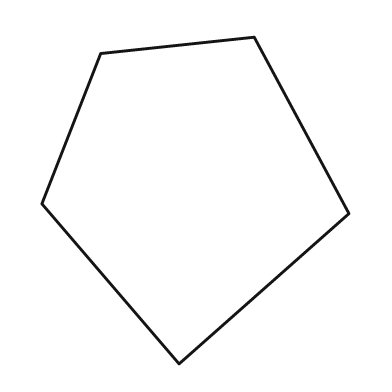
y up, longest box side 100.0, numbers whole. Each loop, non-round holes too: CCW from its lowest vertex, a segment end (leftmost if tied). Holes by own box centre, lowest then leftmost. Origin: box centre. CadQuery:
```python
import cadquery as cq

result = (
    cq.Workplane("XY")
    .moveTo(-5.0, -50.0)
    .lineTo(47.0, -4.0)
    .lineTo(18.0, 50.0)
    .lineTo(-29.0, 45.0)
    .lineTo(-47.0, -1.0)
    .close()
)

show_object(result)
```